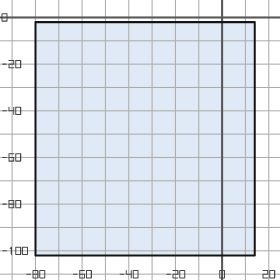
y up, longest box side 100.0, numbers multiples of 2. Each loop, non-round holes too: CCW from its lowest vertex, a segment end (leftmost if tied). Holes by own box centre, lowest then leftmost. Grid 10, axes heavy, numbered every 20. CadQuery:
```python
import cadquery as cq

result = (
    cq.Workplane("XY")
    .moveTo(-80.0, -102.0)
    .lineTo(14.0, -102.0)
    .lineTo(14.0, -2.0)
    .lineTo(-80.0, -2.0)
    .close()
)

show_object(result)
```